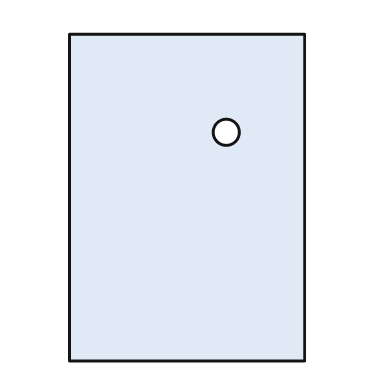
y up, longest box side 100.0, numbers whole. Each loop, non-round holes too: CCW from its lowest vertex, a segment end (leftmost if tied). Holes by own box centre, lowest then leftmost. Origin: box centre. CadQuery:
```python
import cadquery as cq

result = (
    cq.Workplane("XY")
    .moveTo(-36.0, -50.0)
    .lineTo(36.0, -50.0)
    .lineTo(36.0, 50.0)
    .lineTo(-36.0, 50.0)
    .close()
    .moveTo(12.0, 20.0)
    .circle(4.0)
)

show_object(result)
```